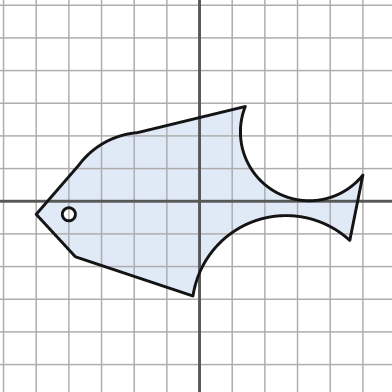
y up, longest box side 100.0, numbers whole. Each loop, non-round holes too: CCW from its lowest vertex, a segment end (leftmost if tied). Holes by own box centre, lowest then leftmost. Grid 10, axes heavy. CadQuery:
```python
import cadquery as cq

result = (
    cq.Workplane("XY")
    .moveTo(-2.0, -29.0)
    .threePointArc((17.0, -6.0), (46.0, -12.0))
    .lineTo(50.0, 8.0)
    .threePointArc((23.0, 3.0), (14.0, 29.0))
    .lineTo(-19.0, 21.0)
    .threePointArc((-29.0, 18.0), (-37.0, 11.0))
    .lineTo(-50.0, -4.0)
    .lineTo(-38.0, -17.0)
    .close()
    .moveTo(-40.0, -4.0)
    .circle(2.0)
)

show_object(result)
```